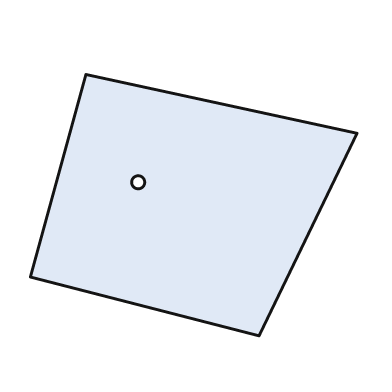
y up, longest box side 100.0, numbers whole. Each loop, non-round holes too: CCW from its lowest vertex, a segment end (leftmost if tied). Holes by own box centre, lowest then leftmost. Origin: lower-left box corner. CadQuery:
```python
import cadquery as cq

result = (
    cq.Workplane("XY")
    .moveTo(70.0, 0.0)
    .lineTo(100.0, 62.0)
    .lineTo(17.0, 80.0)
    .lineTo(0.0, 18.0)
    .close()
    .moveTo(33.0, 47.0)
    .circle(2.0)
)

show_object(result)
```